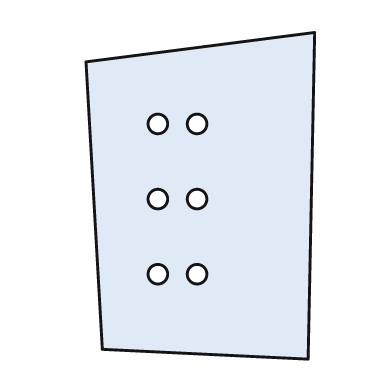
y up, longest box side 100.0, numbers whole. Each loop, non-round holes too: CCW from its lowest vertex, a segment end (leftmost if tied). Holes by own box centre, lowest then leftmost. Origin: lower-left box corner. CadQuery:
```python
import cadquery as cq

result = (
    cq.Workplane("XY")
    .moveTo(68.0, 0.0)
    .lineTo(70.0, 100.0)
    .lineTo(0.0, 91.0)
    .lineTo(5.0, 3.0)
    .close()
    .moveTo(22.0, 26.0)
    .circle(3.0)
    .moveTo(34.0, 26.0)
    .circle(3.0)
    .moveTo(22.0, 49.0)
    .circle(3.0)
    .moveTo(34.0, 49.0)
    .circle(3.0)
    .moveTo(22.0, 72.0)
    .circle(3.0)
    .moveTo(34.0, 72.0)
    .circle(3.0)
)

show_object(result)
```